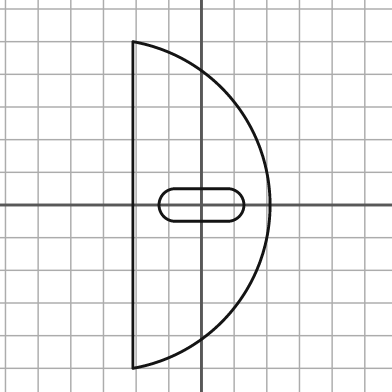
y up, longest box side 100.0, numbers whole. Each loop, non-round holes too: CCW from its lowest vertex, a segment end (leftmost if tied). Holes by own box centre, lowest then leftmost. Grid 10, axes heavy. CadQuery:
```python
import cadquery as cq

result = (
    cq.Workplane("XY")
    .moveTo(-21.0, -50.0)
    .threePointArc((21.0, 0.0), (-21.0, 50.0))
    .close()
    .moveTo(-8.0, -5.0)
    .lineTo(8.0, -5.0)
    .threePointArc((13.0, 0.0), (8.0, 5.0))
    .lineTo(-8.0, 5.0)
    .threePointArc((-13.0, 0.0), (-8.0, -5.0))
    .close()
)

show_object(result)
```